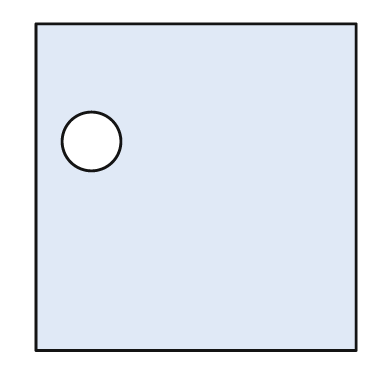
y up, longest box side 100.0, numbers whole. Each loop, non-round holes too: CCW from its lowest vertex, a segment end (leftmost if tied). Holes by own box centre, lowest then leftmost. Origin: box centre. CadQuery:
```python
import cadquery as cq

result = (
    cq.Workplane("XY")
    .moveTo(-49.0, -50.0)
    .lineTo(49.0, -50.0)
    .lineTo(49.0, 50.0)
    .lineTo(-49.0, 50.0)
    .close()
    .moveTo(-32.0, 14.0)
    .circle(9.0)
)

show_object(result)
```